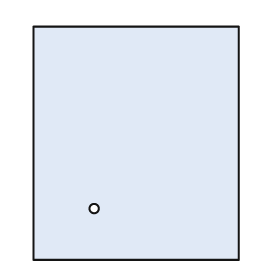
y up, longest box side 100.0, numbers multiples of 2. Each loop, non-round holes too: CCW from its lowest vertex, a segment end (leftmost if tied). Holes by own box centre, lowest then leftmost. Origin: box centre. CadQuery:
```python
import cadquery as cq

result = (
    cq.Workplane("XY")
    .moveTo(-44.0, -50.0)
    .lineTo(44.0, -50.0)
    .lineTo(44.0, 50.0)
    .lineTo(-44.0, 50.0)
    .close()
    .moveTo(-18.0, -28.0)
    .circle(2.0)
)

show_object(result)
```